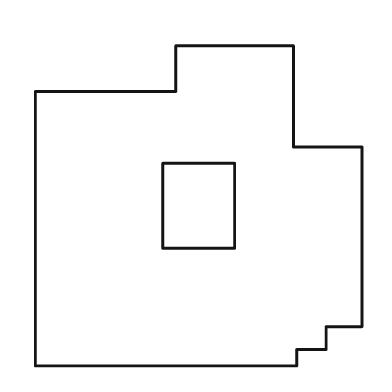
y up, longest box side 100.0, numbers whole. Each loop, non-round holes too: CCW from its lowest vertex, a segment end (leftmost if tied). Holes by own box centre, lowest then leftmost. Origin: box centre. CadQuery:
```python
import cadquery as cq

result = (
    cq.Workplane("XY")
    .moveTo(-50.0, -49.0)
    .lineTo(30.0, -49.0)
    .lineTo(30.0, -44.0)
    .lineTo(39.0, -44.0)
    .lineTo(39.0, -37.0)
    .lineTo(50.0, -37.0)
    .lineTo(50.0, 18.0)
    .lineTo(29.0, 18.0)
    .lineTo(29.0, 49.0)
    .lineTo(-7.0, 49.0)
    .lineTo(-7.0, 35.0)
    .lineTo(-50.0, 35.0)
    .close()
    .moveTo(-11.0, -13.0)
    .lineTo(11.0, -13.0)
    .lineTo(11.0, 13.0)
    .lineTo(-11.0, 13.0)
    .close()
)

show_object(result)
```